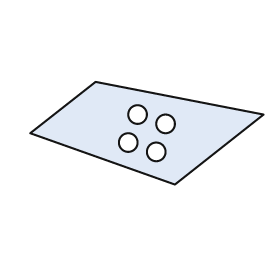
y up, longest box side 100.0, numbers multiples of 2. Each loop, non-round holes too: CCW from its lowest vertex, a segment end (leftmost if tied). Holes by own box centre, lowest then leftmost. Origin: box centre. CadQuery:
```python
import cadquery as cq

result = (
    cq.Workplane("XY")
    .moveTo(12.0, -22.0)
    .lineTo(50.0, 8.0)
    .lineTo(-22.0, 22.0)
    .lineTo(-50.0, 0.0)
    .close()
    .moveTo(4.0, -8.0)
    .circle(4.0)
    .moveTo(-8.0, -4.0)
    .circle(4.0)
    .moveTo(8.0, 4.0)
    .circle(4.0)
    .moveTo(-4.0, 8.0)
    .circle(4.0)
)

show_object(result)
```